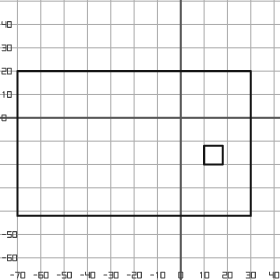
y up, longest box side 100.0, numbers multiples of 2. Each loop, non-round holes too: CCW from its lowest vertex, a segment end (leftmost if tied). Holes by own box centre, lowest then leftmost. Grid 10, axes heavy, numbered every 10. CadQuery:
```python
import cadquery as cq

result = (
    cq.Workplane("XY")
    .moveTo(-70.0, -42.0)
    .lineTo(30.0, -42.0)
    .lineTo(30.0, 20.0)
    .lineTo(-70.0, 20.0)
    .close()
    .moveTo(10.0, -20.0)
    .lineTo(18.0, -20.0)
    .lineTo(18.0, -12.0)
    .lineTo(10.0, -12.0)
    .close()
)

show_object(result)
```